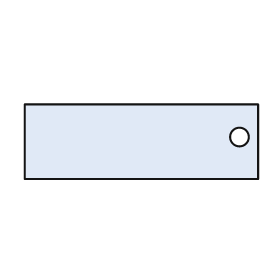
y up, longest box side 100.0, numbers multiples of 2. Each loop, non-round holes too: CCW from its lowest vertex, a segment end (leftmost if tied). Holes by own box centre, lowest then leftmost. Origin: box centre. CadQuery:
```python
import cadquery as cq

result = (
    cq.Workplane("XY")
    .moveTo(-50.0, -16.0)
    .lineTo(50.0, -16.0)
    .lineTo(50.0, 16.0)
    .lineTo(-50.0, 16.0)
    .close()
    .moveTo(42.0, 2.0)
    .circle(4.0)
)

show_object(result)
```